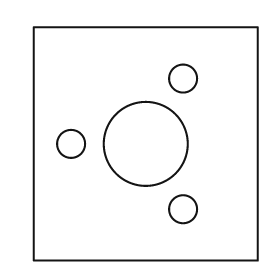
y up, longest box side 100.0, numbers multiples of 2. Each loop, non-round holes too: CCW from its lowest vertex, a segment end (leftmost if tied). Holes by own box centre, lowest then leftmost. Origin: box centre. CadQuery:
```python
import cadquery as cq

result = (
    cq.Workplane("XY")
    .moveTo(-48.0, -50.0)
    .lineTo(48.0, -50.0)
    .lineTo(48.0, 50.0)
    .lineTo(-48.0, 50.0)
    .close()
    .moveTo(16.0, -28.0)
    .circle(6.0)
    .moveTo(-32.0, 0.0)
    .circle(6.0)
    .moveTo(0.0, 0.0)
    .circle(18.0)
    .moveTo(16.0, 28.0)
    .circle(6.0)
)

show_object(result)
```